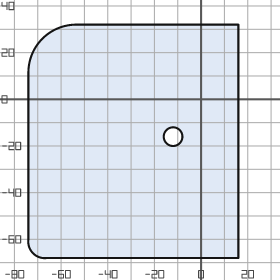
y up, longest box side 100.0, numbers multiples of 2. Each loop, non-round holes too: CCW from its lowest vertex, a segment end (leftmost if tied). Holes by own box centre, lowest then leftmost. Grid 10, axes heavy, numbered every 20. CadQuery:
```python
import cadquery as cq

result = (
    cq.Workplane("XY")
    .moveTo(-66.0, -68.0)
    .lineTo(16.0, -68.0)
    .lineTo(16.0, 32.0)
    .lineTo(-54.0, 32.0)
    .threePointArc((-68.0, 26.0), (-74.0, 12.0))
    .lineTo(-74.0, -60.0)
    .threePointArc((-72.0, -66.0), (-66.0, -68.0))
    .close()
    .moveTo(-12.0, -16.0)
    .circle(4.0)
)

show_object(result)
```